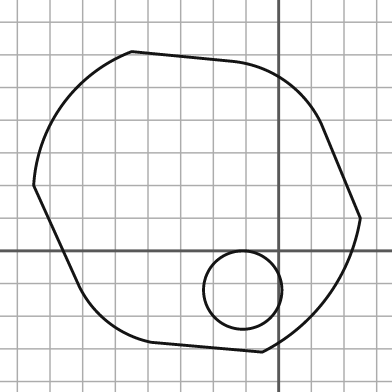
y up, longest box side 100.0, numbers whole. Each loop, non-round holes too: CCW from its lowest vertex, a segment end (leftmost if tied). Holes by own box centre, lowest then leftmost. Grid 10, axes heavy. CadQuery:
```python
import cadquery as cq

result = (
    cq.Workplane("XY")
    .moveTo(-5.0, -31.0)
    .threePointArc((15.0, -14.0), (25.0, 10.0))
    .lineTo(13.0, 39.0)
    .threePointArc((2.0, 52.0), (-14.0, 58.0))
    .lineTo(-45.0, 61.0)
    .threePointArc((-66.0, 45.0), (-75.0, 20.0))
    .lineTo(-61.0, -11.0)
    .threePointArc((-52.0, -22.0), (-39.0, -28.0))
    .close()
    .moveTo(-11.0, -12.0)
    .circle(12.0)
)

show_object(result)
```